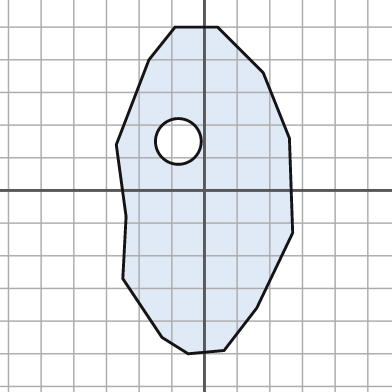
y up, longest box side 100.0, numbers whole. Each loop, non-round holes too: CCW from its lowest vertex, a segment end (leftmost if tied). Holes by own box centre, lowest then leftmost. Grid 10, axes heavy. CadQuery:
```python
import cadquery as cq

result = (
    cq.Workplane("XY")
    .moveTo(-5.0, -50.0)
    .lineTo(6.0, -49.0)
    .lineTo(16.0, -36.0)
    .lineTo(27.0, -13.0)
    .lineTo(26.0, 16.0)
    .lineTo(18.0, 36.0)
    .lineTo(4.0, 50.0)
    .lineTo(-9.0, 50.0)
    .lineTo(-17.0, 40.0)
    .lineTo(-27.0, 14.0)
    .lineTo(-24.0, -8.0)
    .lineTo(-25.0, -27.0)
    .lineTo(-13.0, -45.0)
    .close()
    .moveTo(-8.0, 15.0)
    .circle(7.0)
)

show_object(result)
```